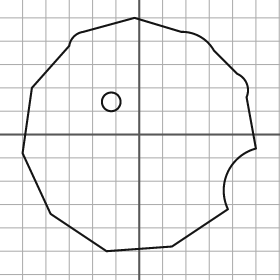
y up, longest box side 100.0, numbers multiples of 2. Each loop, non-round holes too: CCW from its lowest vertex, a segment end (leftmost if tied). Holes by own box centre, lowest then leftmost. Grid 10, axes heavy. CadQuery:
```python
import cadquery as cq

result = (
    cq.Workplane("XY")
    .moveTo(-14.0, -50.0)
    .lineTo(14.0, -48.0)
    .lineTo(38.0, -32.0)
    .threePointArc((38.0, -16.0), (50.0, -6.0))
    .lineTo(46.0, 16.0)
    .threePointArc((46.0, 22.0), (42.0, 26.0))
    .lineTo(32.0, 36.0)
    .threePointArc((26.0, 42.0), (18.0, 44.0))
    .lineTo(-2.0, 50.0)
    .lineTo(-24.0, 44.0)
    .threePointArc((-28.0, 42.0), (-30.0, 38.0))
    .lineTo(-46.0, 20.0)
    .lineTo(-50.0, -8.0)
    .lineTo(-38.0, -34.0)
    .close()
    .moveTo(-12.0, 14.0)
    .circle(4.0)
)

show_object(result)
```